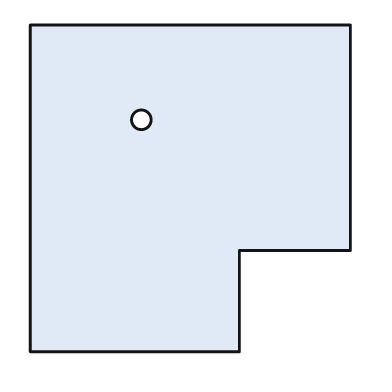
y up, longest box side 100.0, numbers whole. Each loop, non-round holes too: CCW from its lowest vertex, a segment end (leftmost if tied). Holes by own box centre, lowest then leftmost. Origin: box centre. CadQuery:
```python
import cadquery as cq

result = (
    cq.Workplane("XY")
    .moveTo(-49.0, -50.0)
    .lineTo(15.0, -50.0)
    .lineTo(15.0, -19.0)
    .lineTo(49.0, -19.0)
    .lineTo(49.0, 50.0)
    .lineTo(-49.0, 50.0)
    .close()
    .moveTo(-15.0, 21.0)
    .circle(3.0)
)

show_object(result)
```